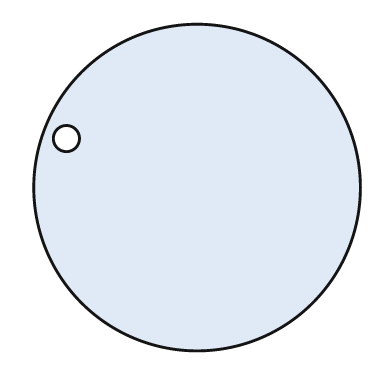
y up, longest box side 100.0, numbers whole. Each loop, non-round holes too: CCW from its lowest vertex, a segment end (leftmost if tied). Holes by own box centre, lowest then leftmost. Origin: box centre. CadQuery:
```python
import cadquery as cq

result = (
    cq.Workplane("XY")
    .moveTo(0.0, 0.0)
    .circle(50.0)
    .moveTo(-40.0, 15.0)
    .circle(4.0)
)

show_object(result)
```